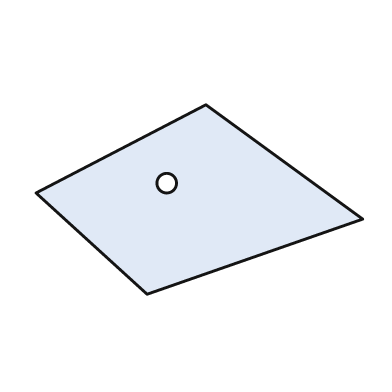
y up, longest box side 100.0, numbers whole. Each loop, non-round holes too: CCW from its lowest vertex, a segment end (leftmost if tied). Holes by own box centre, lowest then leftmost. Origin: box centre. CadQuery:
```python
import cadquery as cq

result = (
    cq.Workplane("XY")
    .moveTo(-16.0, -29.0)
    .lineTo(50.0, -6.0)
    .lineTo(2.0, 29.0)
    .lineTo(-50.0, 2.0)
    .close()
    .moveTo(-10.0, 5.0)
    .circle(3.0)
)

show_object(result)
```